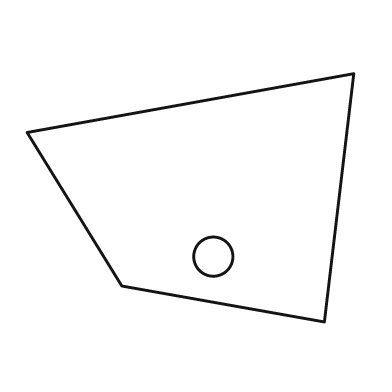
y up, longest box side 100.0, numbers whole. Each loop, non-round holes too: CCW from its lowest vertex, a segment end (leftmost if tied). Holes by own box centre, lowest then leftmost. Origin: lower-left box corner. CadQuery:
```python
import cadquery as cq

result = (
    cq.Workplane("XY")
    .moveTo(91.0, 0.0)
    .lineTo(100.0, 76.0)
    .lineTo(0.0, 58.0)
    .lineTo(29.0, 11.0)
    .close()
    .moveTo(57.0, 20.0)
    .circle(6.0)
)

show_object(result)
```